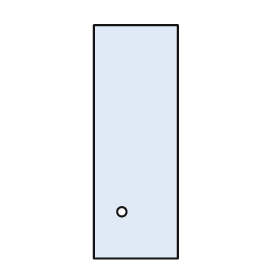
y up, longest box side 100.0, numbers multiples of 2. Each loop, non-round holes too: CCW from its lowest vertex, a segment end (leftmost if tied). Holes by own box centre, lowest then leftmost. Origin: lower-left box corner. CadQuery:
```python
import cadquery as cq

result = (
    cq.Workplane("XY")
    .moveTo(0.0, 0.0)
    .lineTo(36.0, 0.0)
    .lineTo(36.0, 100.0)
    .lineTo(0.0, 100.0)
    .close()
    .moveTo(12.0, 20.0)
    .circle(2.0)
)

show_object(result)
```